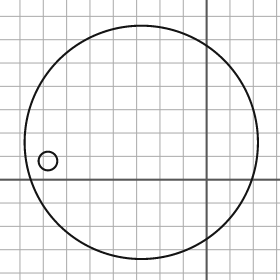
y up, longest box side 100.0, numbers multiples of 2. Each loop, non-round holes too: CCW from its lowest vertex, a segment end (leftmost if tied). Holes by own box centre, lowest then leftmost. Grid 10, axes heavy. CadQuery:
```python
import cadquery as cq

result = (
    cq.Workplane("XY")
    .moveTo(-28.0, 16.0)
    .circle(50.0)
    .moveTo(-68.0, 8.0)
    .circle(4.0)
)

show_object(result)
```